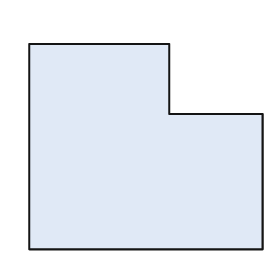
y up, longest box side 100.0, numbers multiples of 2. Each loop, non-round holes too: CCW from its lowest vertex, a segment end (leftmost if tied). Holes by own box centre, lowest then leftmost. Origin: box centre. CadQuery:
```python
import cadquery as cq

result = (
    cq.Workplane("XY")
    .moveTo(-50.0, -44.0)
    .lineTo(50.0, -44.0)
    .lineTo(50.0, 14.0)
    .lineTo(10.0, 14.0)
    .lineTo(10.0, 44.0)
    .lineTo(-50.0, 44.0)
    .close()
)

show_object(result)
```